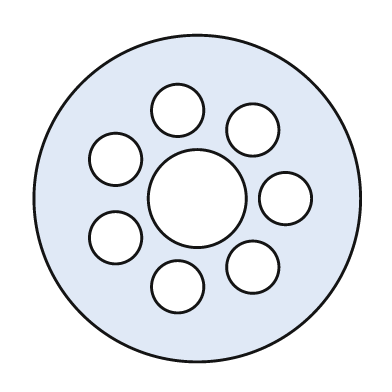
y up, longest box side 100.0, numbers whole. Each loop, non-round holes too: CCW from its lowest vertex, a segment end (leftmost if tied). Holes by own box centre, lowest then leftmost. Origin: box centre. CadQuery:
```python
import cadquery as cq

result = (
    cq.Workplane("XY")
    .moveTo(0.0, 0.0)
    .circle(50.0)
    .moveTo(-6.0, -27.0)
    .circle(8.0)
    .moveTo(17.0, -21.0)
    .circle(8.0)
    .moveTo(-25.0, -12.0)
    .circle(8.0)
    .moveTo(0.0, 0.0)
    .circle(15.0)
    .moveTo(27.0, 0.0)
    .circle(8.0)
    .moveTo(-25.0, 12.0)
    .circle(8.0)
    .moveTo(17.0, 21.0)
    .circle(8.0)
    .moveTo(-6.0, 27.0)
    .circle(8.0)
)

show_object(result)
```